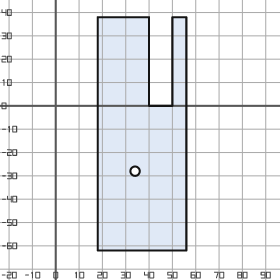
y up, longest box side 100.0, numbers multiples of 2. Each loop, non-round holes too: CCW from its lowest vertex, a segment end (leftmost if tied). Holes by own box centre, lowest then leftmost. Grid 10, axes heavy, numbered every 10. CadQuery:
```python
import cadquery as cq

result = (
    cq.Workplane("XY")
    .moveTo(18.0, -62.0)
    .lineTo(56.0, -62.0)
    .lineTo(56.0, 38.0)
    .lineTo(50.0, 38.0)
    .lineTo(50.0, 0.0)
    .lineTo(40.0, 0.0)
    .lineTo(40.0, 38.0)
    .lineTo(18.0, 38.0)
    .close()
    .moveTo(34.0, -28.0)
    .circle(2.0)
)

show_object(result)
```